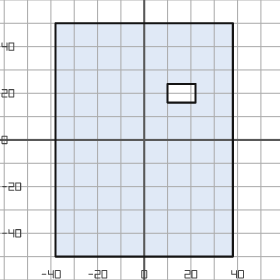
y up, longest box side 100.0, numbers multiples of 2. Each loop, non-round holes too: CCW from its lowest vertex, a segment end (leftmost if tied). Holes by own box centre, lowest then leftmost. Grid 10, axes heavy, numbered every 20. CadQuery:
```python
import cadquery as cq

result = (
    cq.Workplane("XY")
    .moveTo(-38.0, -50.0)
    .lineTo(38.0, -50.0)
    .lineTo(38.0, 50.0)
    .lineTo(-38.0, 50.0)
    .close()
    .moveTo(10.0, 16.0)
    .lineTo(22.0, 16.0)
    .lineTo(22.0, 24.0)
    .lineTo(10.0, 24.0)
    .close()
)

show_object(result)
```